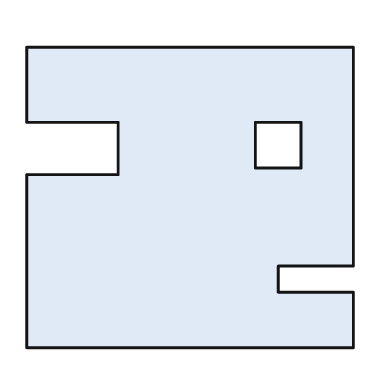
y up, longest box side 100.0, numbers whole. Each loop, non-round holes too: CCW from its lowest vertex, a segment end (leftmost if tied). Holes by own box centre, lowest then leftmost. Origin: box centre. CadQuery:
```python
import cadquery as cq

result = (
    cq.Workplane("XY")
    .moveTo(-50.0, -46.0)
    .lineTo(50.0, -46.0)
    .lineTo(50.0, -29.0)
    .lineTo(27.0, -29.0)
    .lineTo(27.0, -21.0)
    .lineTo(50.0, -21.0)
    .lineTo(50.0, 46.0)
    .lineTo(-50.0, 46.0)
    .lineTo(-50.0, 23.0)
    .lineTo(-22.0, 23.0)
    .lineTo(-22.0, 7.0)
    .lineTo(-50.0, 7.0)
    .close()
    .moveTo(20.0, 9.0)
    .lineTo(34.0, 9.0)
    .lineTo(34.0, 23.0)
    .lineTo(20.0, 23.0)
    .close()
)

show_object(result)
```